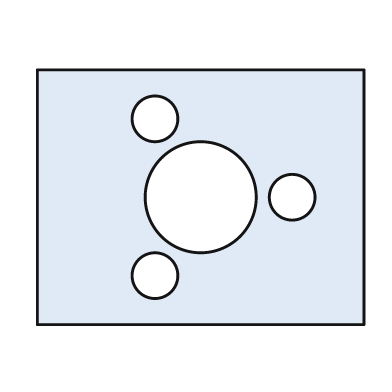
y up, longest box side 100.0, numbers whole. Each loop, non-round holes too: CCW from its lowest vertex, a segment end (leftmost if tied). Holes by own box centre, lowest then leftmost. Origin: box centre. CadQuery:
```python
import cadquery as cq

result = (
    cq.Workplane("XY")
    .moveTo(-50.0, -39.0)
    .lineTo(50.0, -39.0)
    .lineTo(50.0, 39.0)
    .lineTo(-50.0, 39.0)
    .close()
    .moveTo(-14.0, -24.0)
    .circle(7.0)
    .moveTo(0.0, 0.0)
    .circle(17.0)
    .moveTo(28.0, 0.0)
    .circle(7.0)
    .moveTo(-14.0, 24.0)
    .circle(7.0)
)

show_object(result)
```